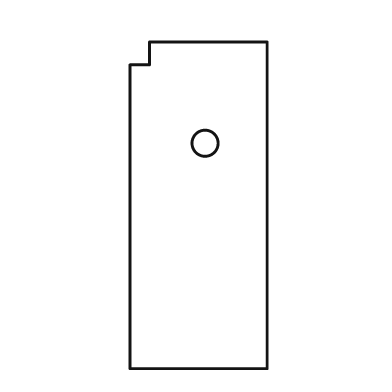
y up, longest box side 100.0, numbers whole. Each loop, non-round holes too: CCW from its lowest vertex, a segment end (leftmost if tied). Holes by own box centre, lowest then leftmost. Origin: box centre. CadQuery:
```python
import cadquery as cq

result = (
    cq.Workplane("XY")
    .moveTo(-21.0, -50.0)
    .lineTo(21.0, -50.0)
    .lineTo(21.0, 50.0)
    .lineTo(-15.0, 50.0)
    .lineTo(-15.0, 43.0)
    .lineTo(-21.0, 43.0)
    .close()
    .moveTo(2.0, 19.0)
    .circle(4.0)
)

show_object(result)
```